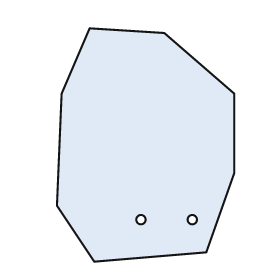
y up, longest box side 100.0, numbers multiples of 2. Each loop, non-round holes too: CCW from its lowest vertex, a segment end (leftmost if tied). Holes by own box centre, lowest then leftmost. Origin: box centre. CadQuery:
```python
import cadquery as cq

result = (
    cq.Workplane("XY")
    .moveTo(-22.0, -50.0)
    .lineTo(26.0, -46.0)
    .lineTo(38.0, -12.0)
    .lineTo(38.0, 22.0)
    .lineTo(8.0, 48.0)
    .lineTo(-24.0, 50.0)
    .lineTo(-36.0, 22.0)
    .lineTo(-38.0, -26.0)
    .close()
    .moveTo(-2.0, -32.0)
    .circle(2.0)
    .moveTo(20.0, -32.0)
    .circle(2.0)
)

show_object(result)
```